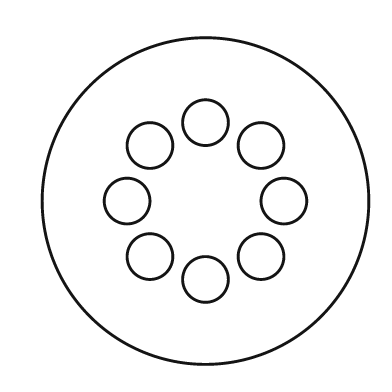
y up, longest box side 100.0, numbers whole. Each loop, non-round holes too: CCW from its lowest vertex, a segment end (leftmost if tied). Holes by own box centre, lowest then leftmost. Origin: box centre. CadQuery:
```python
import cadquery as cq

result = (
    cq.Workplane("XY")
    .moveTo(0.0, 0.0)
    .circle(50.0)
    .moveTo(0.0, -24.0)
    .circle(7.0)
    .moveTo(-17.0, -17.0)
    .circle(7.0)
    .moveTo(17.0, -17.0)
    .circle(7.0)
    .moveTo(-24.0, 0.0)
    .circle(7.0)
    .moveTo(24.0, 0.0)
    .circle(7.0)
    .moveTo(-17.0, 17.0)
    .circle(7.0)
    .moveTo(17.0, 17.0)
    .circle(7.0)
    .moveTo(0.0, 24.0)
    .circle(7.0)
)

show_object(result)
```